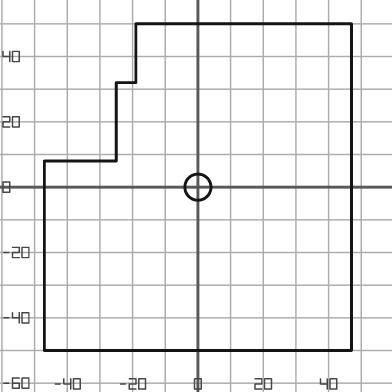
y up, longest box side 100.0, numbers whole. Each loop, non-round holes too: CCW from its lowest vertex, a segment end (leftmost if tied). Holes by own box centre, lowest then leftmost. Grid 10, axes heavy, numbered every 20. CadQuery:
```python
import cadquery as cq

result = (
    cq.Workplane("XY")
    .moveTo(-47.0, -50.0)
    .lineTo(47.0, -50.0)
    .lineTo(47.0, 50.0)
    .lineTo(-19.0, 50.0)
    .lineTo(-19.0, 32.0)
    .lineTo(-25.0, 32.0)
    .lineTo(-25.0, 8.0)
    .lineTo(-47.0, 8.0)
    .close()
    .moveTo(0.0, 0.0)
    .circle(4.0)
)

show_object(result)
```